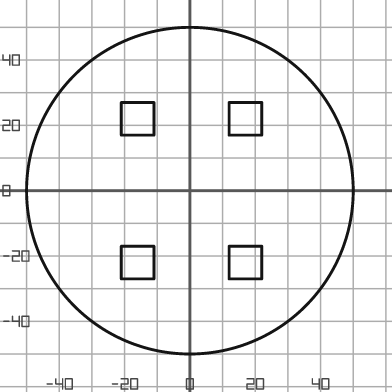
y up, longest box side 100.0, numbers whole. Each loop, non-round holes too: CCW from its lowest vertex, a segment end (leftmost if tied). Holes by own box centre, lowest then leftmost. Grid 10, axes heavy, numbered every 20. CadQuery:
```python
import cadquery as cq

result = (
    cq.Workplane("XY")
    .moveTo(0.0, 0.0)
    .circle(50.0)
    .moveTo(-21.0, -27.0)
    .lineTo(-11.0, -27.0)
    .lineTo(-11.0, -17.0)
    .lineTo(-21.0, -17.0)
    .close()
    .moveTo(12.0, -27.0)
    .lineTo(22.0, -27.0)
    .lineTo(22.0, -17.0)
    .lineTo(12.0, -17.0)
    .close()
    .moveTo(-21.0, 17.0)
    .lineTo(-11.0, 17.0)
    .lineTo(-11.0, 27.0)
    .lineTo(-21.0, 27.0)
    .close()
    .moveTo(12.0, 17.0)
    .lineTo(22.0, 17.0)
    .lineTo(22.0, 27.0)
    .lineTo(12.0, 27.0)
    .close()
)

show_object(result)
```